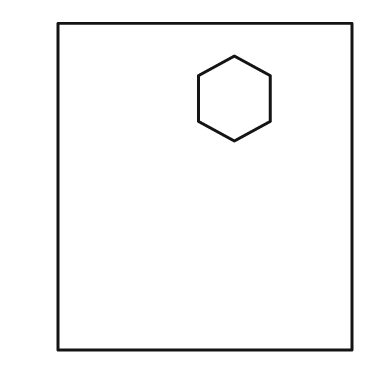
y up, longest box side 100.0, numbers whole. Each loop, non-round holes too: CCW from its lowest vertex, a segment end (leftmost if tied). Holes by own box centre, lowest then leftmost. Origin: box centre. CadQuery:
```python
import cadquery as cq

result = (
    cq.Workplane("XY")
    .moveTo(-45.0, -50.0)
    .lineTo(45.0, -50.0)
    .lineTo(45.0, 50.0)
    .lineTo(-45.0, 50.0)
    .close()
    .moveTo(9.0, 14.0)
    .lineTo(20.0, 20.0)
    .lineTo(20.0, 34.0)
    .lineTo(9.0, 40.0)
    .lineTo(-2.0, 34.0)
    .lineTo(-2.0, 20.0)
    .close()
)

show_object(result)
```